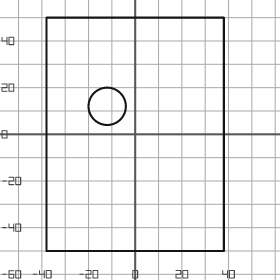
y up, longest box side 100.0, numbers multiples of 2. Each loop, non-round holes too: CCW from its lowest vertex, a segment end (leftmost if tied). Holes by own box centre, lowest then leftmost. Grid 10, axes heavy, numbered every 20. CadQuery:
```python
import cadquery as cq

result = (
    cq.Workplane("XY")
    .moveTo(-38.0, -50.0)
    .lineTo(38.0, -50.0)
    .lineTo(38.0, 50.0)
    .lineTo(-38.0, 50.0)
    .close()
    .moveTo(-12.0, 12.0)
    .circle(8.0)
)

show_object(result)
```